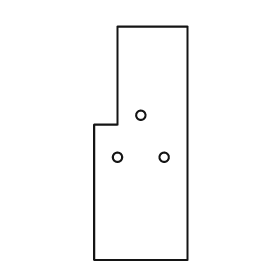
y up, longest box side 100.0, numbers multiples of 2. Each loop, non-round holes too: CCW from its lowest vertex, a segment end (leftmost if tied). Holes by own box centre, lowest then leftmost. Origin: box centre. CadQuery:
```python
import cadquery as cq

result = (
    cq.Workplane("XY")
    .moveTo(-20.0, -50.0)
    .lineTo(20.0, -50.0)
    .lineTo(20.0, 50.0)
    .lineTo(-10.0, 50.0)
    .lineTo(-10.0, 8.0)
    .lineTo(-20.0, 8.0)
    .close()
    .moveTo(-10.0, -6.0)
    .circle(2.0)
    .moveTo(10.0, -6.0)
    .circle(2.0)
    .moveTo(0.0, 12.0)
    .circle(2.0)
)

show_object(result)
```